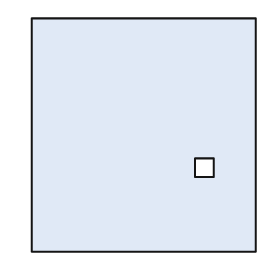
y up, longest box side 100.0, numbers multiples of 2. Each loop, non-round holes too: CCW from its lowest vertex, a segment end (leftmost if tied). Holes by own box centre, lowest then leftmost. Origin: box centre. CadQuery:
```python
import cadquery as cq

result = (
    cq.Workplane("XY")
    .moveTo(-48.0, -50.0)
    .lineTo(48.0, -50.0)
    .lineTo(48.0, 50.0)
    .lineTo(-48.0, 50.0)
    .close()
    .moveTo(22.0, -18.0)
    .lineTo(30.0, -18.0)
    .lineTo(30.0, -10.0)
    .lineTo(22.0, -10.0)
    .close()
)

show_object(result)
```